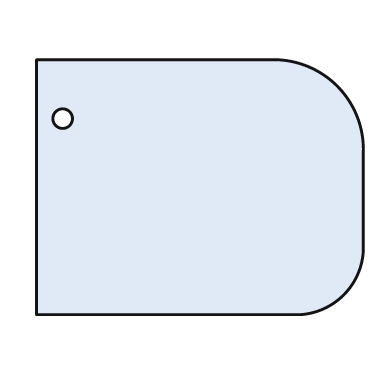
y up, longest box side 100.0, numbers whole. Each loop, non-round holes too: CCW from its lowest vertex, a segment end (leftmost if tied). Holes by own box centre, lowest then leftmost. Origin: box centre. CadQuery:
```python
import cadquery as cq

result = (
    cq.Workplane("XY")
    .moveTo(-50.0, -39.0)
    .lineTo(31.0, -39.0)
    .threePointArc((44.0, -33.0), (50.0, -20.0))
    .lineTo(50.0, 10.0)
    .threePointArc((42.0, 31.0), (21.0, 39.0))
    .lineTo(-50.0, 39.0)
    .close()
    .moveTo(-42.0, 21.0)
    .circle(3.0)
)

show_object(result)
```